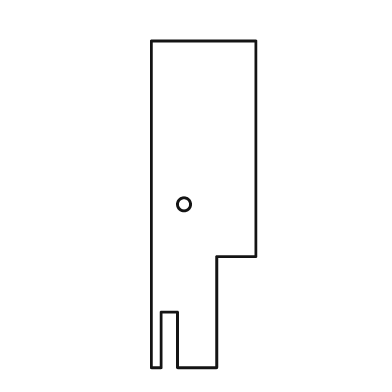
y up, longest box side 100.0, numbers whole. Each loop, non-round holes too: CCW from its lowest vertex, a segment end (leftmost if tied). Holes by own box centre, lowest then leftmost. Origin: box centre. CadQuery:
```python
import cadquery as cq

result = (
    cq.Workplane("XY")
    .moveTo(-16.0, -50.0)
    .lineTo(-13.0, -50.0)
    .lineTo(-13.0, -33.0)
    .lineTo(-8.0, -33.0)
    .lineTo(-8.0, -50.0)
    .lineTo(4.0, -50.0)
    .lineTo(4.0, -16.0)
    .lineTo(16.0, -16.0)
    .lineTo(16.0, 50.0)
    .lineTo(-16.0, 50.0)
    .close()
    .moveTo(-6.0, 0.0)
    .circle(2.0)
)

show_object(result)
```